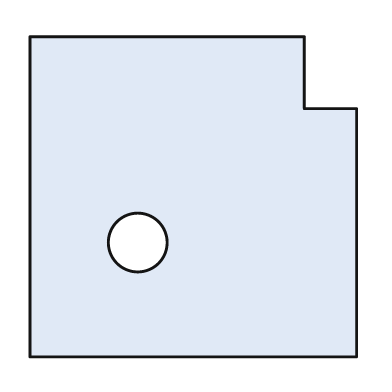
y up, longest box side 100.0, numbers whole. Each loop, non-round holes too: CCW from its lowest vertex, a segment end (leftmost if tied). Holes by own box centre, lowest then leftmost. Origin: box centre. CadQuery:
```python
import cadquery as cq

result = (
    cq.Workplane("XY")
    .moveTo(-50.0, -49.0)
    .lineTo(50.0, -49.0)
    .lineTo(50.0, 27.0)
    .lineTo(34.0, 27.0)
    .lineTo(34.0, 49.0)
    .lineTo(-50.0, 49.0)
    .close()
    .moveTo(-17.0, -14.0)
    .circle(9.0)
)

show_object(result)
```